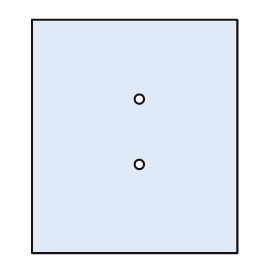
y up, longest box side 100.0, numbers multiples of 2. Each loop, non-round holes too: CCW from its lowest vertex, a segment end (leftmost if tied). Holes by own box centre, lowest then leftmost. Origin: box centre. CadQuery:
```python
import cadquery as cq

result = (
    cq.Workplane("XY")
    .moveTo(-44.0, -50.0)
    .lineTo(44.0, -50.0)
    .lineTo(44.0, 50.0)
    .lineTo(-44.0, 50.0)
    .close()
    .moveTo(2.0, -12.0)
    .circle(2.0)
    .moveTo(2.0, 16.0)
    .circle(2.0)
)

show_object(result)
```